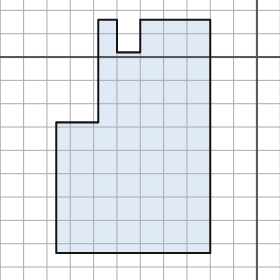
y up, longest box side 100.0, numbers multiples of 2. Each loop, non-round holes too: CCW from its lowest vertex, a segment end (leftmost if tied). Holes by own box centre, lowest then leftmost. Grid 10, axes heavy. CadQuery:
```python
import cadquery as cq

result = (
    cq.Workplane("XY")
    .moveTo(-86.0, -84.0)
    .lineTo(-20.0, -84.0)
    .lineTo(-20.0, 16.0)
    .lineTo(-50.0, 16.0)
    .lineTo(-50.0, 2.0)
    .lineTo(-60.0, 2.0)
    .lineTo(-60.0, 16.0)
    .lineTo(-68.0, 16.0)
    .lineTo(-68.0, -28.0)
    .lineTo(-86.0, -28.0)
    .close()
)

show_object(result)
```